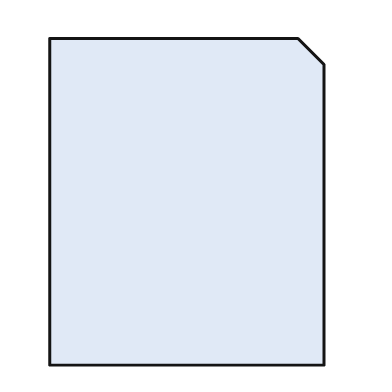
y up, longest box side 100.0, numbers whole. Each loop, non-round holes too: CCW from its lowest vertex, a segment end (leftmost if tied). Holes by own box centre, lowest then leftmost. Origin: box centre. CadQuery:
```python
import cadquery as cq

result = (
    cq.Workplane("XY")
    .moveTo(-42.0, -50.0)
    .lineTo(42.0, -50.0)
    .lineTo(42.0, 42.0)
    .lineTo(34.0, 50.0)
    .lineTo(-42.0, 50.0)
    .close()
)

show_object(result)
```